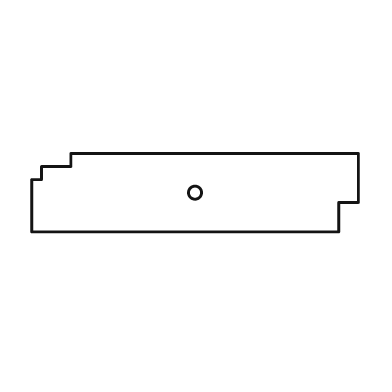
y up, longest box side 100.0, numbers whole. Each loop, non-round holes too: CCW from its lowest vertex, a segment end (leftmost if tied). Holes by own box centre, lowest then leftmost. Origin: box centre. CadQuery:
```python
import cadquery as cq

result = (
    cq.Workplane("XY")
    .moveTo(-50.0, -12.0)
    .lineTo(44.0, -12.0)
    .lineTo(44.0, -3.0)
    .lineTo(50.0, -3.0)
    .lineTo(50.0, 12.0)
    .lineTo(-38.0, 12.0)
    .lineTo(-38.0, 8.0)
    .lineTo(-47.0, 8.0)
    .lineTo(-47.0, 4.0)
    .lineTo(-50.0, 4.0)
    .close()
    .moveTo(0.0, 0.0)
    .circle(2.0)
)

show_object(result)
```